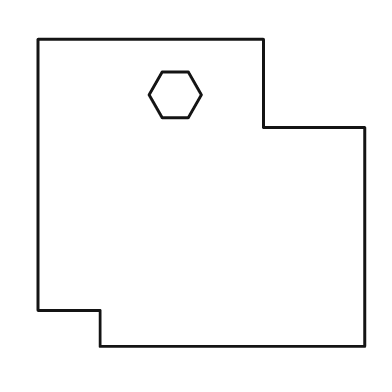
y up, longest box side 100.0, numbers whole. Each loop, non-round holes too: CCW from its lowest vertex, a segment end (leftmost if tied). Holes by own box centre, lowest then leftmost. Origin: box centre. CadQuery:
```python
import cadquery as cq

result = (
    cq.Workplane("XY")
    .moveTo(-31.0, -47.0)
    .lineTo(50.0, -47.0)
    .lineTo(50.0, 20.0)
    .lineTo(19.0, 20.0)
    .lineTo(19.0, 47.0)
    .lineTo(-50.0, 47.0)
    .lineTo(-50.0, -36.0)
    .lineTo(-31.0, -36.0)
    .close()
    .moveTo(-12.0, 23.0)
    .lineTo(-4.0, 23.0)
    .lineTo(0.0, 30.0)
    .lineTo(-4.0, 37.0)
    .lineTo(-12.0, 37.0)
    .lineTo(-16.0, 30.0)
    .close()
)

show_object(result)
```